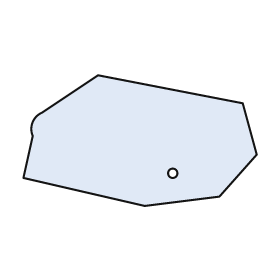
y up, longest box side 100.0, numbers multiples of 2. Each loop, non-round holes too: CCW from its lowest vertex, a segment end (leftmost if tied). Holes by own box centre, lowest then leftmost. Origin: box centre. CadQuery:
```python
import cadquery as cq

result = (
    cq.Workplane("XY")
    .moveTo(2.0, -28.0)
    .lineTo(34.0, -24.0)
    .lineTo(50.0, -6.0)
    .lineTo(44.0, 16.0)
    .lineTo(-18.0, 28.0)
    .lineTo(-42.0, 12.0)
    .threePointArc((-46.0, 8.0), (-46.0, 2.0))
    .lineTo(-50.0, -16.0)
    .close()
    .moveTo(14.0, -14.0)
    .circle(2.0)
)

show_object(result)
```